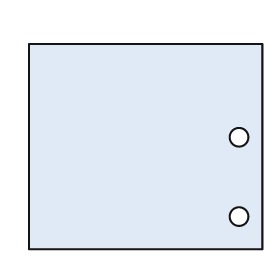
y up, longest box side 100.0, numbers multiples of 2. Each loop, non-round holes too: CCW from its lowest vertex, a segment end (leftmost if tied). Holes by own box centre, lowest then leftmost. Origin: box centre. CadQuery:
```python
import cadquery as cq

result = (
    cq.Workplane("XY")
    .moveTo(-50.0, -44.0)
    .lineTo(50.0, -44.0)
    .lineTo(50.0, 44.0)
    .lineTo(-50.0, 44.0)
    .close()
    .moveTo(40.0, -30.0)
    .circle(4.0)
    .moveTo(40.0, 4.0)
    .circle(4.0)
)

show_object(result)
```